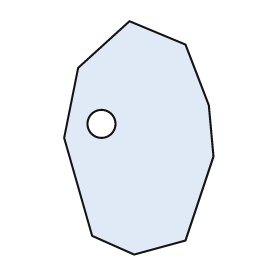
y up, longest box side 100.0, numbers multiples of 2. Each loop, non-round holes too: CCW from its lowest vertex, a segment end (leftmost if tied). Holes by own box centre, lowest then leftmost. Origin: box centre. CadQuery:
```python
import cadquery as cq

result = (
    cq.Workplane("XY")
    .moveTo(-2.0, -50.0)
    .lineTo(20.0, -44.0)
    .lineTo(32.0, -8.0)
    .lineTo(30.0, 14.0)
    .lineTo(20.0, 40.0)
    .lineTo(-4.0, 50.0)
    .lineTo(-26.0, 30.0)
    .lineTo(-32.0, 0.0)
    .lineTo(-20.0, -42.0)
    .close()
    .moveTo(-16.0, 6.0)
    .circle(6.0)
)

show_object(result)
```